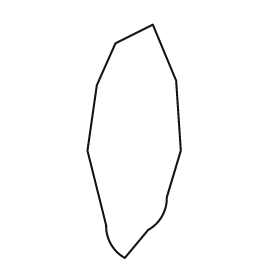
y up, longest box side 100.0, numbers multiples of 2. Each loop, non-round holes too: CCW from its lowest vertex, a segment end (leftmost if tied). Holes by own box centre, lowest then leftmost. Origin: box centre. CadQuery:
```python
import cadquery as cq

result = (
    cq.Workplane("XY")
    .moveTo(-4.0, -50.0)
    .lineTo(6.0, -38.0)
    .threePointArc((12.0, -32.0), (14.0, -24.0))
    .lineTo(20.0, -4.0)
    .lineTo(18.0, 26.0)
    .lineTo(8.0, 50.0)
    .lineTo(-8.0, 42.0)
    .lineTo(-16.0, 24.0)
    .lineTo(-20.0, -4.0)
    .lineTo(-12.0, -36.0)
    .threePointArc((-10.0, -44.0), (-4.0, -50.0))
    .close()
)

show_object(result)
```